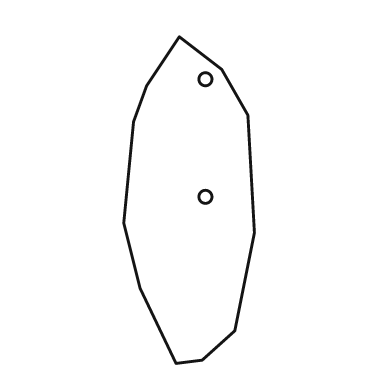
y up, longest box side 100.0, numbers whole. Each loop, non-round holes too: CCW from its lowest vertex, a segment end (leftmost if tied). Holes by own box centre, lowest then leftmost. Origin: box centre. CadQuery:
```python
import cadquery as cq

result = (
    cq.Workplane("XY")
    .moveTo(-4.0, -50.0)
    .lineTo(4.0, -49.0)
    .lineTo(14.0, -40.0)
    .lineTo(20.0, -10.0)
    .lineTo(18.0, 26.0)
    .lineTo(10.0, 40.0)
    .lineTo(-3.0, 50.0)
    .lineTo(-13.0, 35.0)
    .lineTo(-17.0, 24.0)
    .lineTo(-20.0, -7.0)
    .lineTo(-15.0, -27.0)
    .close()
    .moveTo(5.0, 1.0)
    .circle(2.0)
    .moveTo(5.0, 37.0)
    .circle(2.0)
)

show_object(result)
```